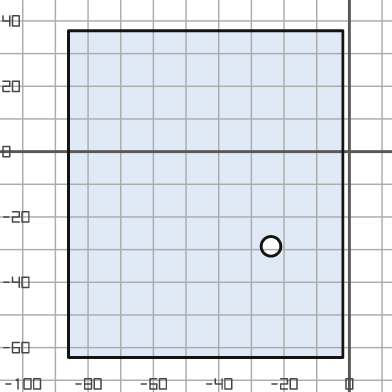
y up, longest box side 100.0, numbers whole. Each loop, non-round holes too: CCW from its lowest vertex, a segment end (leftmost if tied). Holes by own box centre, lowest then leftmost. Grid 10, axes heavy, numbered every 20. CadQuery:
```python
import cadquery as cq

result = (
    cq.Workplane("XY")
    .moveTo(-86.0, -63.0)
    .lineTo(-2.0, -63.0)
    .lineTo(-2.0, 37.0)
    .lineTo(-86.0, 37.0)
    .close()
    .moveTo(-24.0, -29.0)
    .circle(3.0)
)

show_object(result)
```